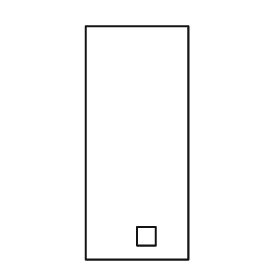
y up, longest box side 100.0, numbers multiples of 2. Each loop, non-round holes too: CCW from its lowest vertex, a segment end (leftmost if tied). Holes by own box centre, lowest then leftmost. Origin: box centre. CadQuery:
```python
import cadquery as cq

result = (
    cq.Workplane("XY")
    .moveTo(-22.0, -50.0)
    .lineTo(22.0, -50.0)
    .lineTo(22.0, 50.0)
    .lineTo(-22.0, 50.0)
    .close()
    .moveTo(0.0, -44.0)
    .lineTo(8.0, -44.0)
    .lineTo(8.0, -36.0)
    .lineTo(0.0, -36.0)
    .close()
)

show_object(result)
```